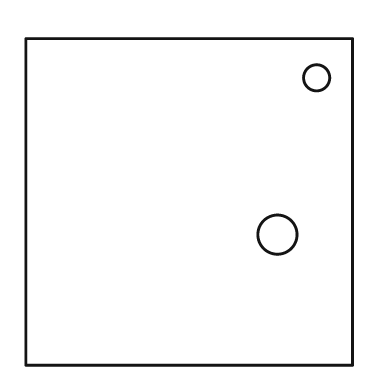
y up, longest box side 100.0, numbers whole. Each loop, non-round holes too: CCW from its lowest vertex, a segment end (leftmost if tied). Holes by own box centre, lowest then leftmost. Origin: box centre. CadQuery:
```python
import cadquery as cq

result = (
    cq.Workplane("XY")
    .moveTo(-50.0, -50.0)
    .lineTo(50.0, -50.0)
    .lineTo(50.0, 50.0)
    .lineTo(-50.0, 50.0)
    .close()
    .moveTo(27.0, -10.0)
    .circle(6.0)
    .moveTo(39.0, 38.0)
    .circle(4.0)
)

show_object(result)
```